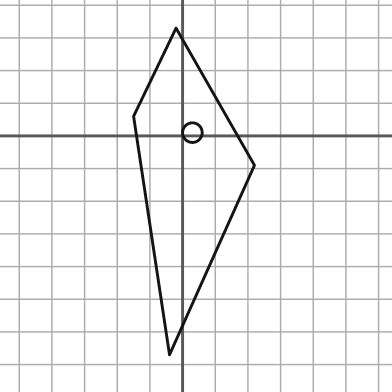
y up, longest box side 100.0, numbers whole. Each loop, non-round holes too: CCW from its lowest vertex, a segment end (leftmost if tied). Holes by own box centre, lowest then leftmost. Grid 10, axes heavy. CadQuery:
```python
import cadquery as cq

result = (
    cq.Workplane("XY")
    .moveTo(-4.0, -67.0)
    .lineTo(22.0, -9.0)
    .lineTo(-2.0, 33.0)
    .lineTo(-15.0, 6.0)
    .close()
    .moveTo(3.0, 1.0)
    .circle(3.0)
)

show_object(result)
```